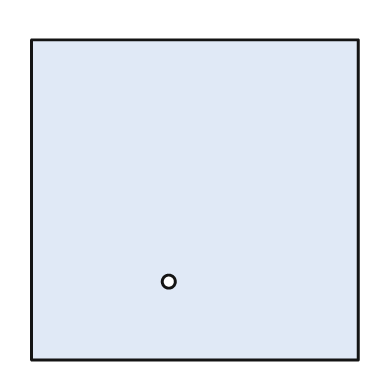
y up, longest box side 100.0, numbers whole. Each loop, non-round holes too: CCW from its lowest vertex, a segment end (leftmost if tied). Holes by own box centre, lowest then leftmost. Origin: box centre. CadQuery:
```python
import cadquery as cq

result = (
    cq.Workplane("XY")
    .moveTo(-50.0, -49.0)
    .lineTo(50.0, -49.0)
    .lineTo(50.0, 49.0)
    .lineTo(-50.0, 49.0)
    .close()
    .moveTo(-8.0, -25.0)
    .circle(2.0)
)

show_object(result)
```